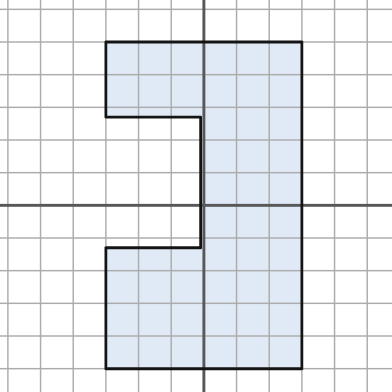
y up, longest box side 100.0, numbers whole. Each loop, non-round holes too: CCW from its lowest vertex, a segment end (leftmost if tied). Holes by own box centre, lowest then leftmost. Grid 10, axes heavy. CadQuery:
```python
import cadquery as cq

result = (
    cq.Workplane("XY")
    .moveTo(-30.0, -50.0)
    .lineTo(30.0, -50.0)
    .lineTo(30.0, 50.0)
    .lineTo(-30.0, 50.0)
    .lineTo(-30.0, 27.0)
    .lineTo(-1.0, 27.0)
    .lineTo(-1.0, -13.0)
    .lineTo(-30.0, -13.0)
    .close()
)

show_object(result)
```